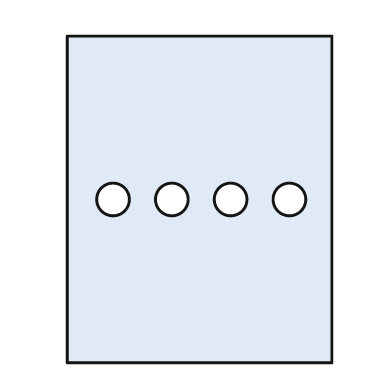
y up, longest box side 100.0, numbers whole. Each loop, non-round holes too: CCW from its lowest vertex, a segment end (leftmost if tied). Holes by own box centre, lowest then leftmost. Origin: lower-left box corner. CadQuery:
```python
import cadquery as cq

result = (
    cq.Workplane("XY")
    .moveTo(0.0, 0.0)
    .lineTo(81.0, 0.0)
    .lineTo(81.0, 100.0)
    .lineTo(0.0, 100.0)
    .close()
    .moveTo(14.0, 50.0)
    .circle(5.0)
    .moveTo(32.0, 50.0)
    .circle(5.0)
    .moveTo(50.0, 50.0)
    .circle(5.0)
    .moveTo(68.0, 50.0)
    .circle(5.0)
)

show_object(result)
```